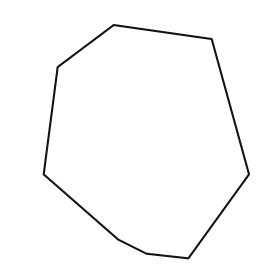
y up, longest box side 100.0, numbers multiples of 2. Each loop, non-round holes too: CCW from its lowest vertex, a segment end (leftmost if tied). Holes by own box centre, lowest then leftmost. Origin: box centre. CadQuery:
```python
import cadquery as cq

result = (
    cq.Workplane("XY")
    .moveTo(18.0, -50.0)
    .lineTo(44.0, -14.0)
    .lineTo(28.0, 44.0)
    .lineTo(-14.0, 50.0)
    .lineTo(-38.0, 32.0)
    .lineTo(-44.0, -14.0)
    .lineTo(-12.0, -42.0)
    .lineTo(0.0, -48.0)
    .close()
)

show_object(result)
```